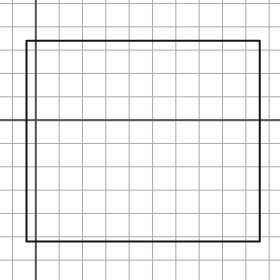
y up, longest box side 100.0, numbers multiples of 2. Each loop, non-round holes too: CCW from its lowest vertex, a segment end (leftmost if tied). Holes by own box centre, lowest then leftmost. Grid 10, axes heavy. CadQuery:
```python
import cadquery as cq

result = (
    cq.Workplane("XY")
    .moveTo(-4.0, -52.0)
    .lineTo(96.0, -52.0)
    .lineTo(96.0, 34.0)
    .lineTo(-4.0, 34.0)
    .close()
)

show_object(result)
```